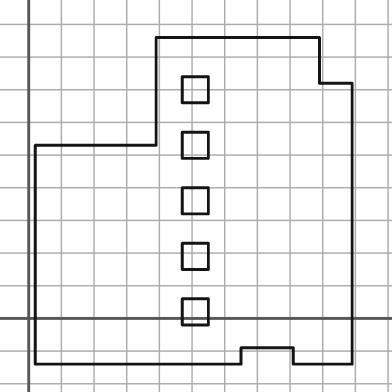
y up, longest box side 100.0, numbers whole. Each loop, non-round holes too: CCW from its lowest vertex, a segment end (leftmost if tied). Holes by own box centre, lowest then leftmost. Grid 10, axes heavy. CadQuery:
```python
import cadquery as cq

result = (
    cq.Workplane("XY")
    .moveTo(2.0, -14.0)
    .lineTo(65.0, -14.0)
    .lineTo(65.0, -9.0)
    .lineTo(81.0, -9.0)
    .lineTo(81.0, -14.0)
    .lineTo(99.0, -14.0)
    .lineTo(99.0, 72.0)
    .lineTo(89.0, 72.0)
    .lineTo(89.0, 86.0)
    .lineTo(39.0, 86.0)
    .lineTo(39.0, 53.0)
    .lineTo(2.0, 53.0)
    .close()
    .moveTo(47.0, -2.0)
    .lineTo(55.0, -2.0)
    .lineTo(55.0, 6.0)
    .lineTo(47.0, 6.0)
    .close()
    .moveTo(47.0, 15.0)
    .lineTo(55.0, 15.0)
    .lineTo(55.0, 23.0)
    .lineTo(47.0, 23.0)
    .close()
    .moveTo(47.0, 32.0)
    .lineTo(55.0, 32.0)
    .lineTo(55.0, 40.0)
    .lineTo(47.0, 40.0)
    .close()
    .moveTo(47.0, 49.0)
    .lineTo(55.0, 49.0)
    .lineTo(55.0, 57.0)
    .lineTo(47.0, 57.0)
    .close()
    .moveTo(47.0, 66.0)
    .lineTo(55.0, 66.0)
    .lineTo(55.0, 74.0)
    .lineTo(47.0, 74.0)
    .close()
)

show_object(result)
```